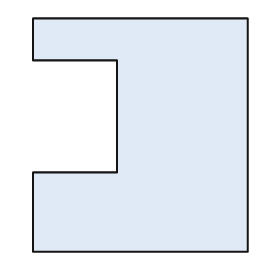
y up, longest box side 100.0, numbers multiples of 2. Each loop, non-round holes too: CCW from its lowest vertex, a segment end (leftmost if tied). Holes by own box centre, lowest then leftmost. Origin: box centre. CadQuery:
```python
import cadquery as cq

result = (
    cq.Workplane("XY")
    .moveTo(-46.0, -50.0)
    .lineTo(46.0, -50.0)
    .lineTo(46.0, 50.0)
    .lineTo(-46.0, 50.0)
    .lineTo(-46.0, 32.0)
    .lineTo(-10.0, 32.0)
    .lineTo(-10.0, -16.0)
    .lineTo(-46.0, -16.0)
    .close()
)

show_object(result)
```